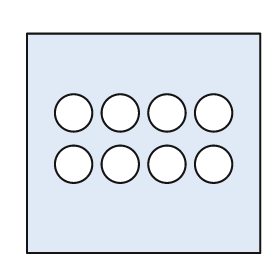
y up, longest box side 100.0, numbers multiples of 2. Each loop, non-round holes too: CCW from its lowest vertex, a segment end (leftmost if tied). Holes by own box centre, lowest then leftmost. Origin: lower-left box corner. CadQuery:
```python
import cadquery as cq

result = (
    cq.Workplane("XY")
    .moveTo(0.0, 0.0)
    .lineTo(100.0, 0.0)
    .lineTo(100.0, 94.0)
    .lineTo(0.0, 94.0)
    .close()
    .moveTo(20.0, 38.0)
    .circle(8.0)
    .moveTo(40.0, 38.0)
    .circle(8.0)
    .moveTo(60.0, 38.0)
    .circle(8.0)
    .moveTo(80.0, 38.0)
    .circle(8.0)
    .moveTo(20.0, 60.0)
    .circle(8.0)
    .moveTo(40.0, 60.0)
    .circle(8.0)
    .moveTo(60.0, 60.0)
    .circle(8.0)
    .moveTo(80.0, 60.0)
    .circle(8.0)
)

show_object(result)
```